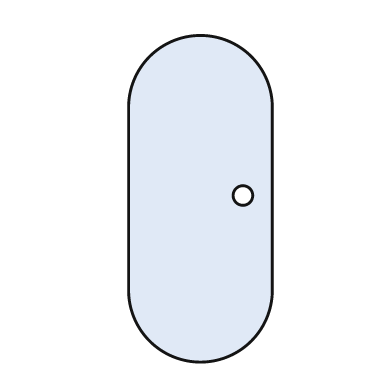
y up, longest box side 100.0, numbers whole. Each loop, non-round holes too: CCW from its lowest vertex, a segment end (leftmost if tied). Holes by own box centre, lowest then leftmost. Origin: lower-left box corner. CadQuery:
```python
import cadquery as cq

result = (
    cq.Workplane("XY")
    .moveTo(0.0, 22.0)
    .threePointArc((22.0, 0.0), (44.0, 22.0))
    .lineTo(44.0, 78.0)
    .threePointArc((22.0, 100.0), (0.0, 78.0))
    .close()
    .moveTo(35.0, 51.0)
    .circle(3.0)
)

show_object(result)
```